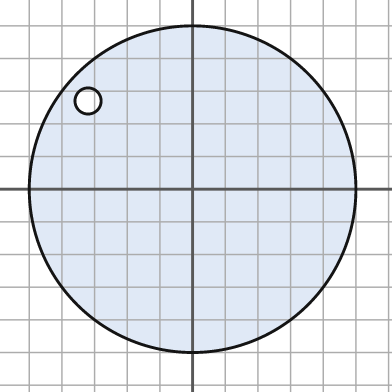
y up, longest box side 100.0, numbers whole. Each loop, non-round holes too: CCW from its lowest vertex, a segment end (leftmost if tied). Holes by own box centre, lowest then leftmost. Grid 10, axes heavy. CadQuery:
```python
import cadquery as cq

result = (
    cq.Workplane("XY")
    .moveTo(0.0, 0.0)
    .circle(50.0)
    .moveTo(-32.0, 27.0)
    .circle(4.0)
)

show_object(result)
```